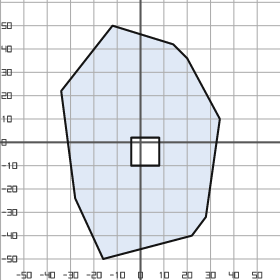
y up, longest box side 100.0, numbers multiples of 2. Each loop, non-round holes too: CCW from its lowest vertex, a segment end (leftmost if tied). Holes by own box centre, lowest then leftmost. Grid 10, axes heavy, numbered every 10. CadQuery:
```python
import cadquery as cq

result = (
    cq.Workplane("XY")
    .moveTo(-16.0, -50.0)
    .lineTo(22.0, -40.0)
    .lineTo(28.0, -32.0)
    .lineTo(34.0, 10.0)
    .lineTo(20.0, 36.0)
    .lineTo(14.0, 42.0)
    .lineTo(-12.0, 50.0)
    .lineTo(-34.0, 22.0)
    .lineTo(-28.0, -24.0)
    .close()
    .moveTo(-4.0, -10.0)
    .lineTo(8.0, -10.0)
    .lineTo(8.0, 2.0)
    .lineTo(-4.0, 2.0)
    .close()
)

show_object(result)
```